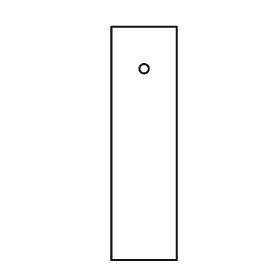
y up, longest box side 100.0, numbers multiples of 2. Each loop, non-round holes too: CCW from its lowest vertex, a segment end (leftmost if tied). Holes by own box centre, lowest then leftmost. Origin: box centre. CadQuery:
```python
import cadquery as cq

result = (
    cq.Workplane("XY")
    .moveTo(-14.0, -50.0)
    .lineTo(14.0, -50.0)
    .lineTo(14.0, 50.0)
    .lineTo(-14.0, 50.0)
    .close()
    .moveTo(0.0, 32.0)
    .circle(2.0)
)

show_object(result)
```